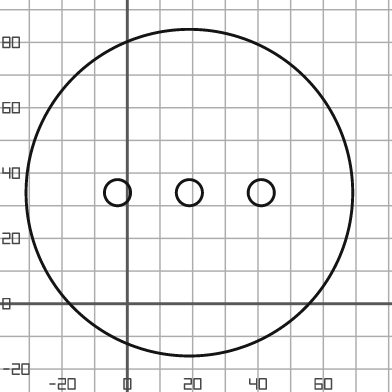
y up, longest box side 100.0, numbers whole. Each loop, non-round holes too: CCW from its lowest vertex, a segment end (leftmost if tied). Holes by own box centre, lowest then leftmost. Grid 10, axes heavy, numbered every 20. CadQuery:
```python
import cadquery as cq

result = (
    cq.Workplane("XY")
    .moveTo(19.0, 34.0)
    .circle(50.0)
    .moveTo(-3.0, 34.0)
    .circle(4.0)
    .moveTo(19.0, 34.0)
    .circle(4.0)
    .moveTo(41.0, 34.0)
    .circle(4.0)
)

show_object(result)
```